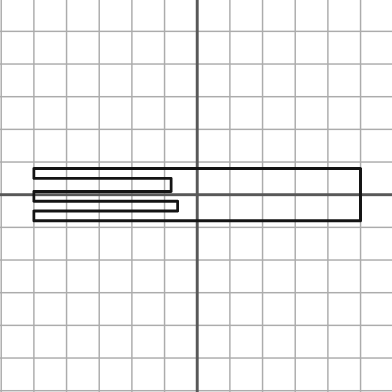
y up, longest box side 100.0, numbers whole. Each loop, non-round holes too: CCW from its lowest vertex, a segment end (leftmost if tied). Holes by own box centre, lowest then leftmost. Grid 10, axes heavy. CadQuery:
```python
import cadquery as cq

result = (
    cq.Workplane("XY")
    .moveTo(-50.0, -8.0)
    .lineTo(50.0, -8.0)
    .lineTo(50.0, 8.0)
    .lineTo(-50.0, 8.0)
    .lineTo(-50.0, 5.0)
    .lineTo(-8.0, 5.0)
    .lineTo(-8.0, 1.0)
    .lineTo(-50.0, 1.0)
    .lineTo(-50.0, -2.0)
    .lineTo(-6.0, -2.0)
    .lineTo(-6.0, -5.0)
    .lineTo(-50.0, -5.0)
    .close()
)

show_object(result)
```